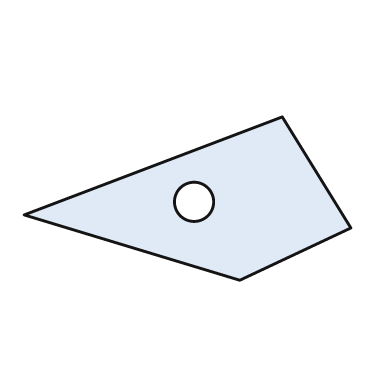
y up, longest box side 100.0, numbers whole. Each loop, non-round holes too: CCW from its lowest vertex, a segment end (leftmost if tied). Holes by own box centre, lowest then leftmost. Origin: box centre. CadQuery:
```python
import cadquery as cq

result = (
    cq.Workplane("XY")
    .moveTo(16.0, -25.0)
    .lineTo(50.0, -9.0)
    .lineTo(29.0, 25.0)
    .lineTo(-50.0, -5.0)
    .close()
    .moveTo(2.0, -1.0)
    .circle(6.0)
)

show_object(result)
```